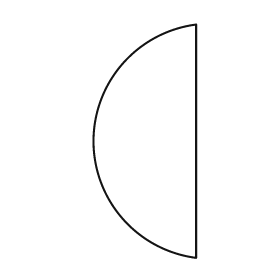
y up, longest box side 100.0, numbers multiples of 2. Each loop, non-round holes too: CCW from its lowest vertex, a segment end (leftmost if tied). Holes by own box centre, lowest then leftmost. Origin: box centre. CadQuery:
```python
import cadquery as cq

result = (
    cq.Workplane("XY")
    .moveTo(22.0, -50.0)
    .lineTo(22.0, 50.0)
    .threePointArc((-22.0, 0.0), (22.0, -50.0))
    .close()
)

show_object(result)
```